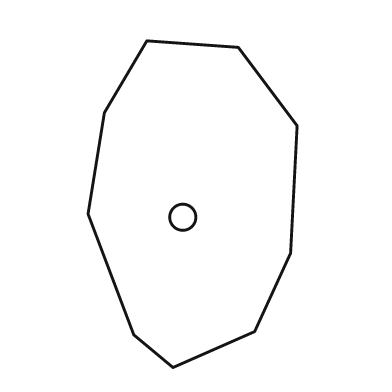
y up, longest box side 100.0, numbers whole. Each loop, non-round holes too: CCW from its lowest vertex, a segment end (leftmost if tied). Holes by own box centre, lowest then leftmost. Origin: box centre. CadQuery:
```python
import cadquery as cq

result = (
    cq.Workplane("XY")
    .moveTo(-6.0, -50.0)
    .lineTo(19.0, -39.0)
    .lineTo(30.0, -15.0)
    .lineTo(32.0, 24.0)
    .lineTo(14.0, 48.0)
    .lineTo(-14.0, 50.0)
    .lineTo(-27.0, 28.0)
    .lineTo(-32.0, -3.0)
    .lineTo(-18.0, -40.0)
    .close()
    .moveTo(-3.0, -4.0)
    .circle(4.0)
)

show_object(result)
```